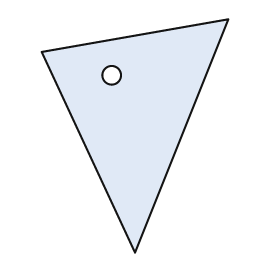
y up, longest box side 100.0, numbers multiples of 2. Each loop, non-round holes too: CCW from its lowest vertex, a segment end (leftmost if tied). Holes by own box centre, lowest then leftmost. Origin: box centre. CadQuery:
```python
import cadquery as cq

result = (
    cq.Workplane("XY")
    .moveTo(0.0, -50.0)
    .lineTo(40.0, 50.0)
    .lineTo(-40.0, 36.0)
    .close()
    .moveTo(-10.0, 26.0)
    .circle(4.0)
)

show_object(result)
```